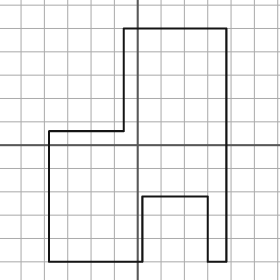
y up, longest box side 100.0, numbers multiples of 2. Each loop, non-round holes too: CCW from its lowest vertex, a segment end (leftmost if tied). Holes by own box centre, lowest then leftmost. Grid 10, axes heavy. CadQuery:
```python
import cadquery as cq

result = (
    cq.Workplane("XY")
    .moveTo(-38.0, -50.0)
    .lineTo(2.0, -50.0)
    .lineTo(2.0, -22.0)
    .lineTo(30.0, -22.0)
    .lineTo(30.0, -50.0)
    .lineTo(38.0, -50.0)
    .lineTo(38.0, 50.0)
    .lineTo(-6.0, 50.0)
    .lineTo(-6.0, 6.0)
    .lineTo(-38.0, 6.0)
    .close()
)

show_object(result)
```